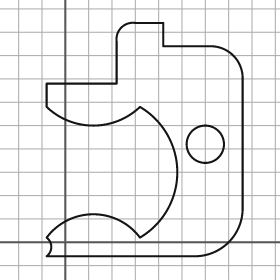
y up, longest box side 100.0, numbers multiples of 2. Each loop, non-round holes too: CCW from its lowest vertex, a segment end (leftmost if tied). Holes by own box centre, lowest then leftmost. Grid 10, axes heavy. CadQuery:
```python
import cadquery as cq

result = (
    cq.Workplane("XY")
    .moveTo(-8.0, -6.0)
    .lineTo(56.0, -6.0)
    .threePointArc((70.0, 0.0), (76.0, 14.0))
    .lineTo(76.0, 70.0)
    .threePointArc((72.0, 80.0), (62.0, 84.0))
    .lineTo(42.0, 84.0)
    .lineTo(42.0, 94.0)
    .lineTo(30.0, 94.0)
    .threePointArc((24.0, 92.0), (22.0, 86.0))
    .lineTo(22.0, 68.0)
    .lineTo(-8.0, 68.0)
    .lineTo(-8.0, 58.0)
    .threePointArc((12.0, 50.0), (32.0, 58.0))
    .threePointArc((48.0, 30.0), (32.0, 2.0))
    .threePointArc((12.0, 12.0), (-8.0, 2.0))
    .threePointArc((-6.0, -2.0), (-8.0, -6.0))
    .close()
    .moveTo(60.0, 42.0)
    .circle(8.0)
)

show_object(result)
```